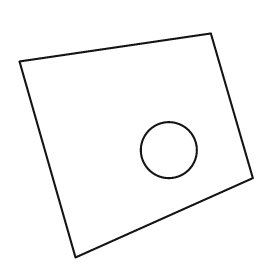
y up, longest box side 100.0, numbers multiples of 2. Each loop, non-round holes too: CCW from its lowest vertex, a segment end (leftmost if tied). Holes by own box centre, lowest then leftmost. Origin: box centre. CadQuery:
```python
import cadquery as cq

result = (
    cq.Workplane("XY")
    .moveTo(-26.0, -48.0)
    .lineTo(50.0, -14.0)
    .lineTo(32.0, 48.0)
    .lineTo(-50.0, 36.0)
    .close()
    .moveTo(14.0, -2.0)
    .circle(12.0)
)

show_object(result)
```